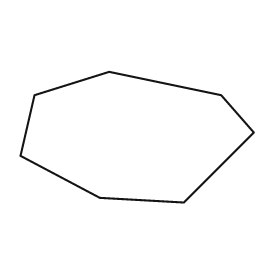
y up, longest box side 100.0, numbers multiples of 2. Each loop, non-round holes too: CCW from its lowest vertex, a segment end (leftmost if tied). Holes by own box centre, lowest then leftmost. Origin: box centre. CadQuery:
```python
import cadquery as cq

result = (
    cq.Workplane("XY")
    .moveTo(20.0, -28.0)
    .lineTo(50.0, 2.0)
    .lineTo(36.0, 18.0)
    .lineTo(-12.0, 28.0)
    .lineTo(-44.0, 18.0)
    .lineTo(-50.0, -8.0)
    .lineTo(-16.0, -26.0)
    .close()
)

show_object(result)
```